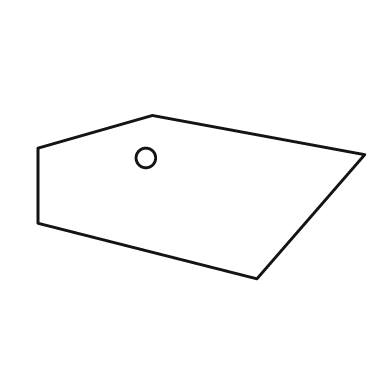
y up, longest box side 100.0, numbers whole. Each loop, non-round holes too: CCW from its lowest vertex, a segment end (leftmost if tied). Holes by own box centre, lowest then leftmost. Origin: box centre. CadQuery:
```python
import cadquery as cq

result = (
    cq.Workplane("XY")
    .moveTo(17.0, -25.0)
    .lineTo(50.0, 13.0)
    .lineTo(-15.0, 25.0)
    .lineTo(-50.0, 15.0)
    .lineTo(-50.0, -8.0)
    .close()
    .moveTo(-17.0, 12.0)
    .circle(3.0)
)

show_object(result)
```